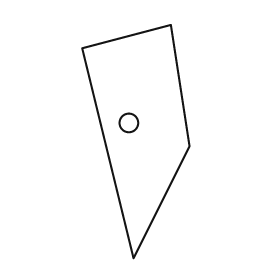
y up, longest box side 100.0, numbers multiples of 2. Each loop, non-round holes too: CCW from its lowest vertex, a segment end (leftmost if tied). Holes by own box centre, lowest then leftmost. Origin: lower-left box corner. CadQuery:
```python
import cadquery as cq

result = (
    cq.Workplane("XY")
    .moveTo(22.0, 0.0)
    .lineTo(46.0, 48.0)
    .lineTo(38.0, 100.0)
    .lineTo(0.0, 90.0)
    .close()
    .moveTo(20.0, 58.0)
    .circle(4.0)
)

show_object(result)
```